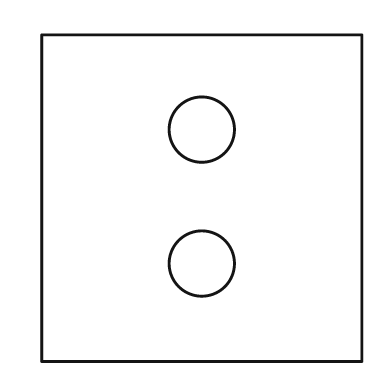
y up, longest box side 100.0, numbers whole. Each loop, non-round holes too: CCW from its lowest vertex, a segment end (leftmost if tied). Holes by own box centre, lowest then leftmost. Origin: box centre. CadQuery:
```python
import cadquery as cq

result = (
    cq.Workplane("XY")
    .moveTo(-49.0, -50.0)
    .lineTo(49.0, -50.0)
    .lineTo(49.0, 50.0)
    .lineTo(-49.0, 50.0)
    .close()
    .moveTo(0.0, -20.0)
    .circle(10.0)
    .moveTo(0.0, 21.0)
    .circle(10.0)
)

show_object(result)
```